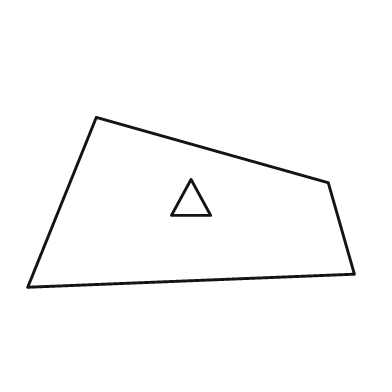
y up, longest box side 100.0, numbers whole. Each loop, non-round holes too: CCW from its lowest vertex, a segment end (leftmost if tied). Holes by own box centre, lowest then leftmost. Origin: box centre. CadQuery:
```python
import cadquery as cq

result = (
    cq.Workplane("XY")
    .moveTo(-50.0, -26.0)
    .lineTo(50.0, -22.0)
    .lineTo(42.0, 6.0)
    .lineTo(-29.0, 26.0)
    .close()
    .moveTo(-6.0, -4.0)
    .lineTo(6.0, -4.0)
    .lineTo(0.0, 7.0)
    .close()
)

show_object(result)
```